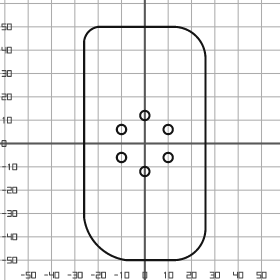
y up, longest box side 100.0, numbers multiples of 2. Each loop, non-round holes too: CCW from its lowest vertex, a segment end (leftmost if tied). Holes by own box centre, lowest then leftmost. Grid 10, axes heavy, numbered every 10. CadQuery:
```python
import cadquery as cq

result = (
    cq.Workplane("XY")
    .moveTo(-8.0, -50.0)
    .lineTo(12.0, -50.0)
    .threePointArc((22.0, -46.0), (26.0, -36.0))
    .lineTo(26.0, 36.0)
    .threePointArc((22.0, 46.0), (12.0, 50.0))
    .lineTo(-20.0, 50.0)
    .threePointArc((-24.0, 48.0), (-26.0, 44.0))
    .lineTo(-26.0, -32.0)
    .threePointArc((-20.0, -44.0), (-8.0, -50.0))
    .close()
    .moveTo(0.0, -12.0)
    .circle(2.0)
    .moveTo(-10.0, -6.0)
    .circle(2.0)
    .moveTo(10.0, -6.0)
    .circle(2.0)
    .moveTo(-10.0, 6.0)
    .circle(2.0)
    .moveTo(10.0, 6.0)
    .circle(2.0)
    .moveTo(0.0, 12.0)
    .circle(2.0)
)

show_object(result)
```